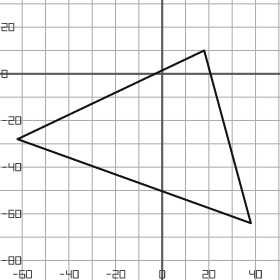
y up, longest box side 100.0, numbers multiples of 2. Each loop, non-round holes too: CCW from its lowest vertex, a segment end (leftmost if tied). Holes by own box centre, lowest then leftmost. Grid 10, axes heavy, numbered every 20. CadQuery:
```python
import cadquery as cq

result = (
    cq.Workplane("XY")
    .moveTo(38.0, -64.0)
    .lineTo(18.0, 10.0)
    .lineTo(-62.0, -28.0)
    .close()
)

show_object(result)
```